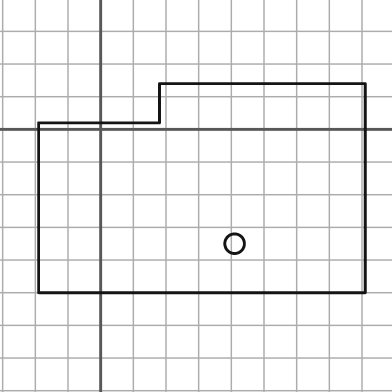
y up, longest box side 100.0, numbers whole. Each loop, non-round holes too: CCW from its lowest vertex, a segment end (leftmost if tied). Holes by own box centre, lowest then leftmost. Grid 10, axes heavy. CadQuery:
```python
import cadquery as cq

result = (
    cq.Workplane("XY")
    .moveTo(-19.0, -50.0)
    .lineTo(81.0, -50.0)
    .lineTo(81.0, 14.0)
    .lineTo(18.0, 14.0)
    .lineTo(18.0, 2.0)
    .lineTo(-19.0, 2.0)
    .close()
    .moveTo(41.0, -35.0)
    .circle(3.0)
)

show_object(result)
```